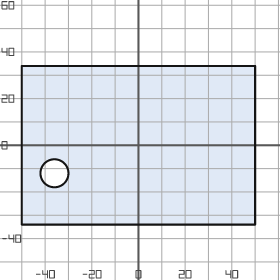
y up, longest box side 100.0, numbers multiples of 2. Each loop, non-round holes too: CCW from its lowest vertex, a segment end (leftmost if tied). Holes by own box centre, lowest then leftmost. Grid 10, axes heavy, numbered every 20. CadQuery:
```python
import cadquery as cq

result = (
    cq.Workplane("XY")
    .moveTo(-50.0, -34.0)
    .lineTo(50.0, -34.0)
    .lineTo(50.0, 34.0)
    .lineTo(-50.0, 34.0)
    .close()
    .moveTo(-36.0, -12.0)
    .circle(6.0)
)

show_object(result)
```